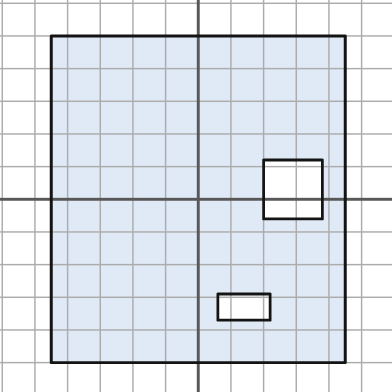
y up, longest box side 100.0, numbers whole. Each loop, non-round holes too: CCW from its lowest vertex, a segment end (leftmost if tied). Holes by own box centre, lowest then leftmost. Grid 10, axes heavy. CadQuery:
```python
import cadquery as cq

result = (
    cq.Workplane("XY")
    .moveTo(-45.0, -50.0)
    .lineTo(45.0, -50.0)
    .lineTo(45.0, 50.0)
    .lineTo(-45.0, 50.0)
    .close()
    .moveTo(6.0, -37.0)
    .lineTo(22.0, -37.0)
    .lineTo(22.0, -29.0)
    .lineTo(6.0, -29.0)
    .close()
    .moveTo(20.0, -6.0)
    .lineTo(38.0, -6.0)
    .lineTo(38.0, 12.0)
    .lineTo(20.0, 12.0)
    .close()
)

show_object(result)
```